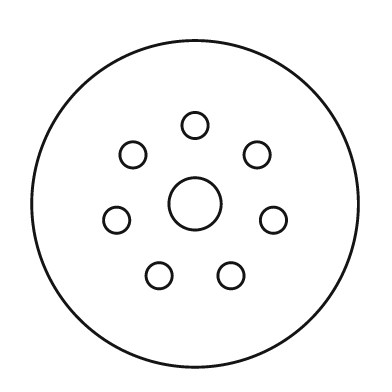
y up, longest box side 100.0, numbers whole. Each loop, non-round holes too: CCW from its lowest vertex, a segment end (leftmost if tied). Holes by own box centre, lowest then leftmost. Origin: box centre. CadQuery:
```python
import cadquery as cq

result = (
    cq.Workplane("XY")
    .moveTo(0.0, 0.0)
    .circle(50.0)
    .moveTo(-11.0, -22.0)
    .circle(4.0)
    .moveTo(11.0, -22.0)
    .circle(4.0)
    .moveTo(-24.0, -5.0)
    .circle(4.0)
    .moveTo(24.0, -5.0)
    .circle(4.0)
    .moveTo(0.0, 0.0)
    .circle(8.0)
    .moveTo(-19.0, 15.0)
    .circle(4.0)
    .moveTo(19.0, 15.0)
    .circle(4.0)
    .moveTo(0.0, 24.0)
    .circle(4.0)
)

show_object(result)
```